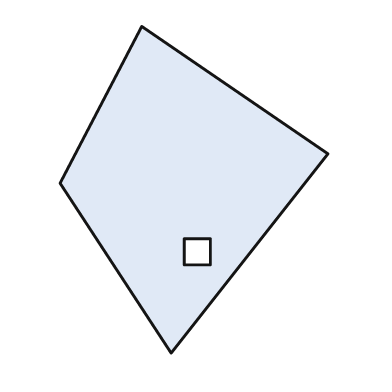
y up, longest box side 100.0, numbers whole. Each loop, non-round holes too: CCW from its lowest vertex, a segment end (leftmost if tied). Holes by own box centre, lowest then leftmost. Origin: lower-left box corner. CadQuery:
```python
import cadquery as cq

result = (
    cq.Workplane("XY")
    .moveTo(34.0, 0.0)
    .lineTo(82.0, 61.0)
    .lineTo(25.0, 100.0)
    .lineTo(0.0, 52.0)
    .close()
    .moveTo(38.0, 27.0)
    .lineTo(46.0, 27.0)
    .lineTo(46.0, 35.0)
    .lineTo(38.0, 35.0)
    .close()
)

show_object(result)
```